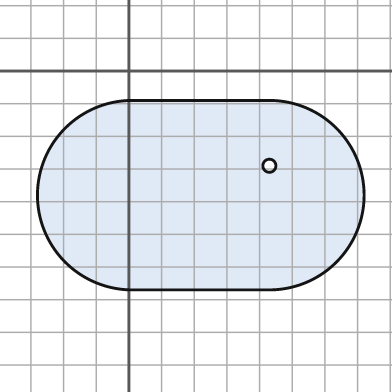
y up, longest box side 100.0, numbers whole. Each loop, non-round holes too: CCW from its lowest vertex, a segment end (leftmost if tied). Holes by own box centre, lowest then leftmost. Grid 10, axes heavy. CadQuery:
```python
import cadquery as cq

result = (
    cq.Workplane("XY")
    .moveTo(1.0, -67.0)
    .lineTo(43.0, -67.0)
    .threePointArc((72.0, -38.0), (43.0, -9.0))
    .lineTo(1.0, -9.0)
    .threePointArc((-28.0, -38.0), (1.0, -67.0))
    .close()
    .moveTo(43.0, -29.0)
    .circle(2.0)
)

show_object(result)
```